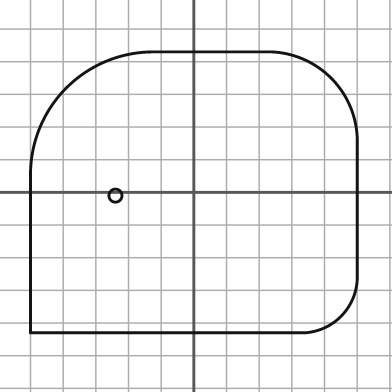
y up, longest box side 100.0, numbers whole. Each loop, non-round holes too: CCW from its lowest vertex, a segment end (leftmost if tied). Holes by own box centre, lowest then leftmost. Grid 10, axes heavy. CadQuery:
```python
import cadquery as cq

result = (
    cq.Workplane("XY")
    .moveTo(-50.0, -43.0)
    .lineTo(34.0, -43.0)
    .threePointArc((45.0, -38.0), (50.0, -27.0))
    .lineTo(50.0, 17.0)
    .threePointArc((42.0, 35.0), (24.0, 43.0))
    .lineTo(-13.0, 43.0)
    .threePointArc((-39.0, 32.0), (-50.0, 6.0))
    .close()
    .moveTo(-24.0, -1.0)
    .circle(2.0)
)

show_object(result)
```